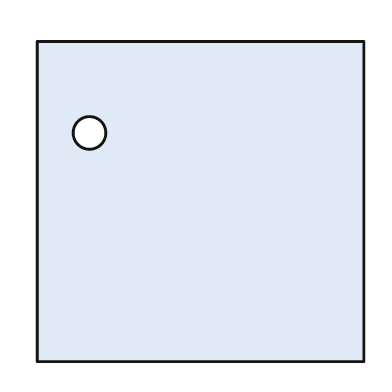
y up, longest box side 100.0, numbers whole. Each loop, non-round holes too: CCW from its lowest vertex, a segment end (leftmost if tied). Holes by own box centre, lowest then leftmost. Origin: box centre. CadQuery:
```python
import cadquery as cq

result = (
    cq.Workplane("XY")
    .moveTo(-50.0, -49.0)
    .lineTo(50.0, -49.0)
    .lineTo(50.0, 49.0)
    .lineTo(-50.0, 49.0)
    .close()
    .moveTo(-34.0, 21.0)
    .circle(5.0)
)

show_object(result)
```